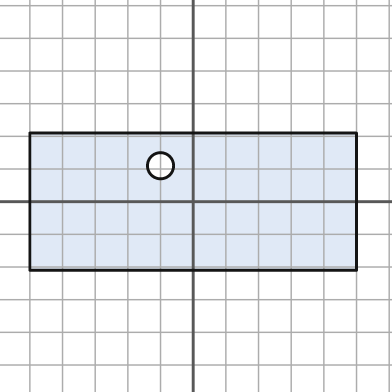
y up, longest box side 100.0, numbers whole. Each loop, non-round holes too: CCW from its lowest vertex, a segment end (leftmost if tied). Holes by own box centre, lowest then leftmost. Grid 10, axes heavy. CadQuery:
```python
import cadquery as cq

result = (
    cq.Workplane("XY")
    .moveTo(-50.0, -21.0)
    .lineTo(50.0, -21.0)
    .lineTo(50.0, 21.0)
    .lineTo(-50.0, 21.0)
    .close()
    .moveTo(-10.0, 11.0)
    .circle(4.0)
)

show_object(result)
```